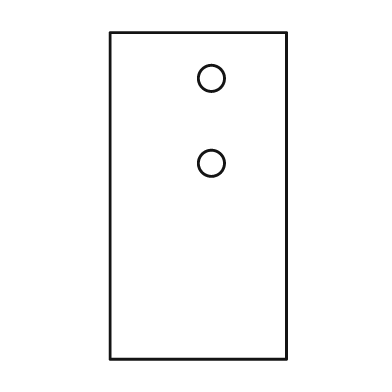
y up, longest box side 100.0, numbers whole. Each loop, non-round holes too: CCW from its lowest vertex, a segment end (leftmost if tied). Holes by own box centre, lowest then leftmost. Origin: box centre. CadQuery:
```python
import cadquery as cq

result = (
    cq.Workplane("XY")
    .moveTo(-27.0, -50.0)
    .lineTo(27.0, -50.0)
    .lineTo(27.0, 50.0)
    .lineTo(-27.0, 50.0)
    .close()
    .moveTo(4.0, 10.0)
    .circle(4.0)
    .moveTo(4.0, 36.0)
    .circle(4.0)
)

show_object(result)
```